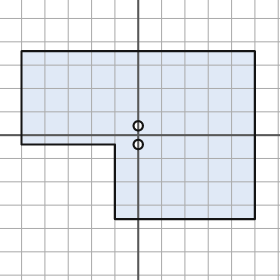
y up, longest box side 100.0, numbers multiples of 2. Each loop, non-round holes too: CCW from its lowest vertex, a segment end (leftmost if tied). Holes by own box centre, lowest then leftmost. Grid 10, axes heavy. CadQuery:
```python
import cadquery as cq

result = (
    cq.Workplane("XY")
    .moveTo(-10.0, -36.0)
    .lineTo(50.0, -36.0)
    .lineTo(50.0, 36.0)
    .lineTo(-50.0, 36.0)
    .lineTo(-50.0, -4.0)
    .lineTo(-10.0, -4.0)
    .close()
    .moveTo(0.0, -4.0)
    .circle(2.0)
    .moveTo(0.0, 4.0)
    .circle(2.0)
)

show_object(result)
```